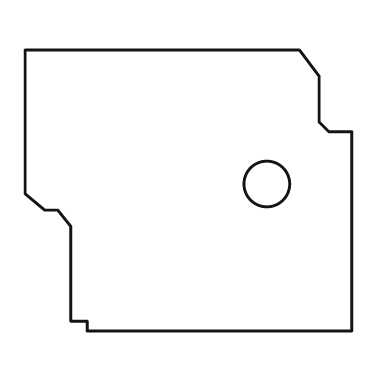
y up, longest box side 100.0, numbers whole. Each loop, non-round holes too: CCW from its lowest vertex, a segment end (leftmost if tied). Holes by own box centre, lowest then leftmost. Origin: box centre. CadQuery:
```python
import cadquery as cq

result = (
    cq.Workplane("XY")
    .moveTo(-31.0, -43.0)
    .lineTo(50.0, -43.0)
    .lineTo(50.0, 18.0)
    .lineTo(43.0, 18.0)
    .lineTo(40.0, 21.0)
    .lineTo(40.0, 35.0)
    .lineTo(34.0, 43.0)
    .lineTo(-50.0, 43.0)
    .lineTo(-50.0, -1.0)
    .lineTo(-44.0, -6.0)
    .lineTo(-40.0, -6.0)
    .lineTo(-36.0, -11.0)
    .lineTo(-36.0, -40.0)
    .lineTo(-31.0, -40.0)
    .close()
    .moveTo(24.0, 2.0)
    .circle(7.0)
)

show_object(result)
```